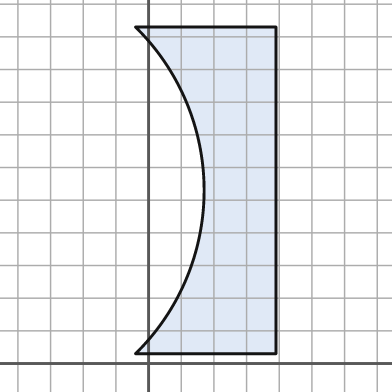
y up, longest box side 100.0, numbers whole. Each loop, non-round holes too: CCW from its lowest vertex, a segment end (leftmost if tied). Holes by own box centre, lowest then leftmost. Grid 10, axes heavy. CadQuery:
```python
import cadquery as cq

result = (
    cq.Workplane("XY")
    .moveTo(-4.0, 3.0)
    .lineTo(39.0, 3.0)
    .lineTo(39.0, 103.0)
    .lineTo(-4.0, 103.0)
    .threePointArc((17.0, 53.0), (-4.0, 3.0))
    .close()
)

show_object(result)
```